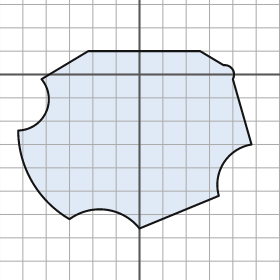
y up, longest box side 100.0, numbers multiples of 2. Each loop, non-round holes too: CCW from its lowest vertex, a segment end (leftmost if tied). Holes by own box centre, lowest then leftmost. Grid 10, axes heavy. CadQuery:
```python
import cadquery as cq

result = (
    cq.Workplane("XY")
    .moveTo(0.0, -66.0)
    .lineTo(34.0, -52.0)
    .threePointArc((36.0, -38.0), (48.0, -30.0))
    .lineTo(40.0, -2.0)
    .threePointArc((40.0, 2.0), (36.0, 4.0))
    .lineTo(26.0, 10.0)
    .lineTo(-22.0, 10.0)
    .lineTo(-42.0, -2.0)
    .threePointArc((-40.0, -16.0), (-52.0, -24.0))
    .threePointArc((-46.0, -46.0), (-30.0, -62.0))
    .threePointArc((-14.0, -58.0), (0.0, -66.0))
    .close()
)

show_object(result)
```